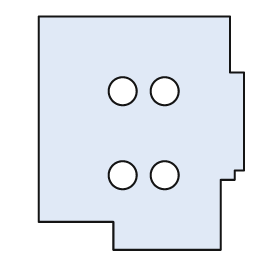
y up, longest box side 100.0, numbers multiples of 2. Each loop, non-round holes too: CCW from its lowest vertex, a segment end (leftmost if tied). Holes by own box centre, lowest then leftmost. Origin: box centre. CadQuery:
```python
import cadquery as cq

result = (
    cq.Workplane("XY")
    .moveTo(-12.0, -50.0)
    .lineTo(34.0, -50.0)
    .lineTo(34.0, -20.0)
    .lineTo(40.0, -20.0)
    .lineTo(40.0, -16.0)
    .lineTo(44.0, -16.0)
    .lineTo(44.0, 26.0)
    .lineTo(38.0, 26.0)
    .lineTo(38.0, 50.0)
    .lineTo(-44.0, 50.0)
    .lineTo(-44.0, -38.0)
    .lineTo(-12.0, -38.0)
    .close()
    .moveTo(-8.0, -18.0)
    .circle(6.0)
    .moveTo(10.0, -18.0)
    .circle(6.0)
    .moveTo(-8.0, 18.0)
    .circle(6.0)
    .moveTo(10.0, 18.0)
    .circle(6.0)
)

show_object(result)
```